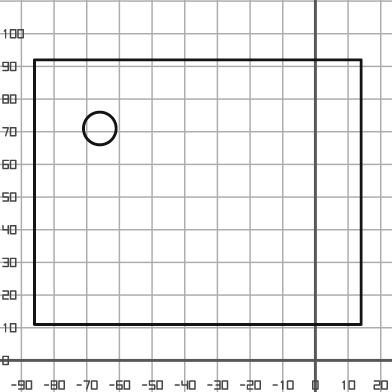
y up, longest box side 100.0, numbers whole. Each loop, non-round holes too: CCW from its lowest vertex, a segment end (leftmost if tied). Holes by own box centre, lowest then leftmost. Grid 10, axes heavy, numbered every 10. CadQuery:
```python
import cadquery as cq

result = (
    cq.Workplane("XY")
    .moveTo(-86.0, 11.0)
    .lineTo(14.0, 11.0)
    .lineTo(14.0, 92.0)
    .lineTo(-86.0, 92.0)
    .close()
    .moveTo(-66.0, 71.0)
    .circle(5.0)
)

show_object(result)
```